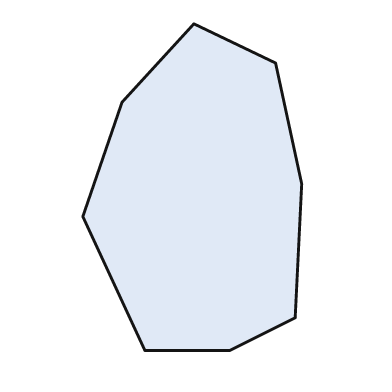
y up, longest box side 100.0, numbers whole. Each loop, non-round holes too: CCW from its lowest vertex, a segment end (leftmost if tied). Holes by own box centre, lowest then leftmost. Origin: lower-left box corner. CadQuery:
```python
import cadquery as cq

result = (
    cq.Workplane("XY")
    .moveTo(19.0, 0.0)
    .lineTo(45.0, 0.0)
    .lineTo(65.0, 10.0)
    .lineTo(67.0, 51.0)
    .lineTo(59.0, 88.0)
    .lineTo(34.0, 100.0)
    .lineTo(12.0, 76.0)
    .lineTo(0.0, 41.0)
    .close()
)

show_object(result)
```